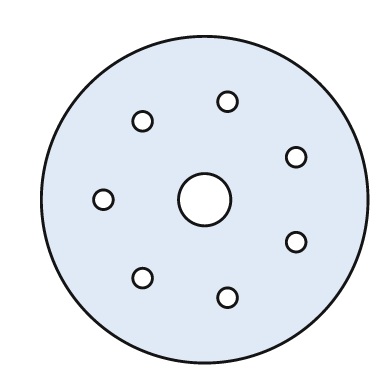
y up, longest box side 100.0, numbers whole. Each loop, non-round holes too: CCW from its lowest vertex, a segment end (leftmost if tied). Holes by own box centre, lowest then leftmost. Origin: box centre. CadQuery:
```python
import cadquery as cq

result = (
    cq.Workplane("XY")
    .moveTo(0.0, 0.0)
    .circle(50.0)
    .moveTo(7.0, -30.0)
    .circle(3.0)
    .moveTo(-19.0, -24.0)
    .circle(3.0)
    .moveTo(28.0, -13.0)
    .circle(3.0)
    .moveTo(-31.0, 0.0)
    .circle(3.0)
    .moveTo(0.0, 0.0)
    .circle(8.0)
    .moveTo(28.0, 13.0)
    .circle(3.0)
    .moveTo(-19.0, 24.0)
    .circle(3.0)
    .moveTo(7.0, 30.0)
    .circle(3.0)
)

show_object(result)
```